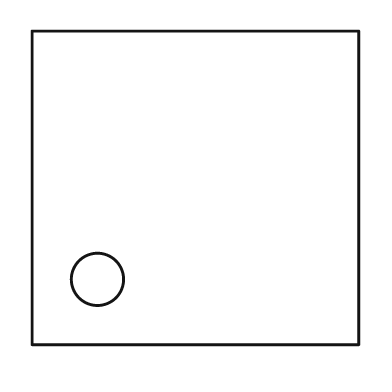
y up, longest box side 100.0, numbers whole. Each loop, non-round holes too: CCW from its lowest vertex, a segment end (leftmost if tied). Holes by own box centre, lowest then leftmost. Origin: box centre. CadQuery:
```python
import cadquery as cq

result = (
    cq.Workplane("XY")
    .moveTo(-50.0, -48.0)
    .lineTo(50.0, -48.0)
    .lineTo(50.0, 48.0)
    .lineTo(-50.0, 48.0)
    .close()
    .moveTo(-30.0, -28.0)
    .circle(8.0)
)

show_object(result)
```